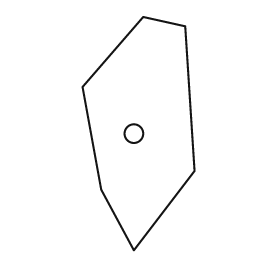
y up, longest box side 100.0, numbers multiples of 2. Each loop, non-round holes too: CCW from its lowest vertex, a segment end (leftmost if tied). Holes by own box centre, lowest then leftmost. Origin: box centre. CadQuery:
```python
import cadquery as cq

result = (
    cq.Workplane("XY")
    .moveTo(-2.0, -50.0)
    .lineTo(24.0, -16.0)
    .lineTo(20.0, 46.0)
    .lineTo(2.0, 50.0)
    .lineTo(-24.0, 20.0)
    .lineTo(-16.0, -24.0)
    .close()
    .moveTo(-2.0, 0.0)
    .circle(4.0)
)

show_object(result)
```